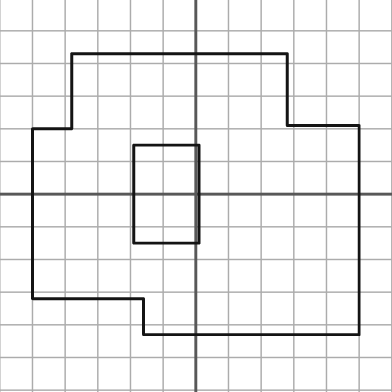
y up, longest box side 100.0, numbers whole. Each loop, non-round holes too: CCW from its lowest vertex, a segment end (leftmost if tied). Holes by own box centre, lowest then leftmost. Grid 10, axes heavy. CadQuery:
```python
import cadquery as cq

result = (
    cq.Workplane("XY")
    .moveTo(-16.0, -43.0)
    .lineTo(50.0, -43.0)
    .lineTo(50.0, 21.0)
    .lineTo(28.0, 21.0)
    .lineTo(28.0, 43.0)
    .lineTo(-38.0, 43.0)
    .lineTo(-38.0, 20.0)
    .lineTo(-50.0, 20.0)
    .lineTo(-50.0, -32.0)
    .lineTo(-16.0, -32.0)
    .close()
    .moveTo(-19.0, -15.0)
    .lineTo(1.0, -15.0)
    .lineTo(1.0, 15.0)
    .lineTo(-19.0, 15.0)
    .close()
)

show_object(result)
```